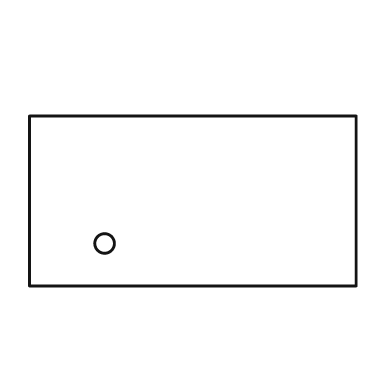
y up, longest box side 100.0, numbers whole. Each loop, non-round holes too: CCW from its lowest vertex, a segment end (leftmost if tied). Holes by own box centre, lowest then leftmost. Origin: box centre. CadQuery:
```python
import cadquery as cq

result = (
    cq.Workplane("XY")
    .moveTo(-50.0, -26.0)
    .lineTo(50.0, -26.0)
    .lineTo(50.0, 26.0)
    .lineTo(-50.0, 26.0)
    .close()
    .moveTo(-27.0, -13.0)
    .circle(3.0)
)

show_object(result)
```